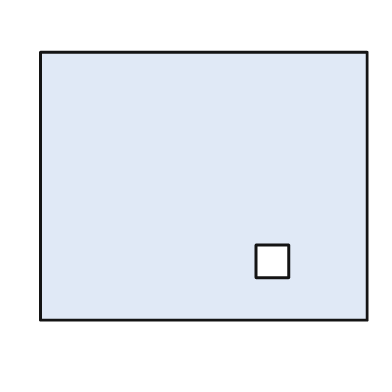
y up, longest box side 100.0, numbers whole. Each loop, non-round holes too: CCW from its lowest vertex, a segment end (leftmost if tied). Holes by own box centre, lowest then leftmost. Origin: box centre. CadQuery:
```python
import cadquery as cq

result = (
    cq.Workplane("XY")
    .moveTo(-50.0, -41.0)
    .lineTo(50.0, -41.0)
    .lineTo(50.0, 41.0)
    .lineTo(-50.0, 41.0)
    .close()
    .moveTo(16.0, -28.0)
    .lineTo(26.0, -28.0)
    .lineTo(26.0, -18.0)
    .lineTo(16.0, -18.0)
    .close()
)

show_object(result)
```